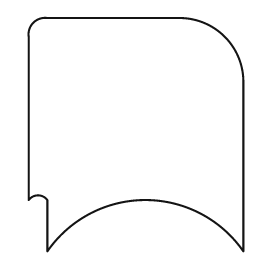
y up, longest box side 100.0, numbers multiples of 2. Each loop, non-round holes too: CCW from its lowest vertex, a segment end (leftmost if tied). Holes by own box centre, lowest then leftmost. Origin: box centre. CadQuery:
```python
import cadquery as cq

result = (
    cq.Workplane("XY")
    .moveTo(-38.0, -50.0)
    .threePointArc((4.0, -28.0), (46.0, -50.0))
    .lineTo(46.0, 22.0)
    .threePointArc((38.0, 42.0), (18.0, 50.0))
    .lineTo(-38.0, 50.0)
    .threePointArc((-44.0, 48.0), (-46.0, 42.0))
    .lineTo(-46.0, -28.0)
    .threePointArc((-42.0, -26.0), (-38.0, -28.0))
    .close()
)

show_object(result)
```